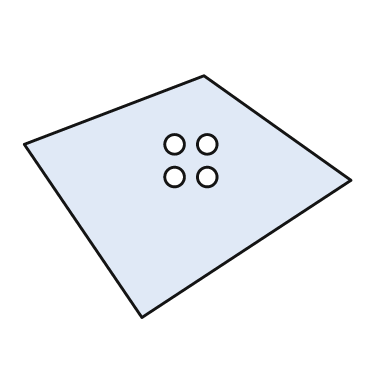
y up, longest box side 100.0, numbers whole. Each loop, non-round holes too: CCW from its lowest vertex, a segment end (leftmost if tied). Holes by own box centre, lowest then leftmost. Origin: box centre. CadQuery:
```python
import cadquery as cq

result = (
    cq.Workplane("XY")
    .moveTo(-14.0, -37.0)
    .lineTo(50.0, 5.0)
    .lineTo(5.0, 37.0)
    .lineTo(-50.0, 16.0)
    .close()
    .moveTo(-4.0, 6.0)
    .circle(3.0)
    .moveTo(6.0, 6.0)
    .circle(3.0)
    .moveTo(-4.0, 16.0)
    .circle(3.0)
    .moveTo(6.0, 16.0)
    .circle(3.0)
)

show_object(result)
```